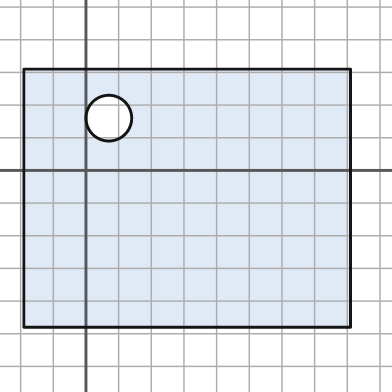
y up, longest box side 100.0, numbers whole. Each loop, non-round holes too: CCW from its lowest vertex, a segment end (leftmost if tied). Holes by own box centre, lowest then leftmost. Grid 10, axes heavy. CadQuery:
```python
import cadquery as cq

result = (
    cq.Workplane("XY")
    .moveTo(-19.0, -48.0)
    .lineTo(81.0, -48.0)
    .lineTo(81.0, 31.0)
    .lineTo(-19.0, 31.0)
    .close()
    .moveTo(7.0, 16.0)
    .circle(7.0)
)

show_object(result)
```